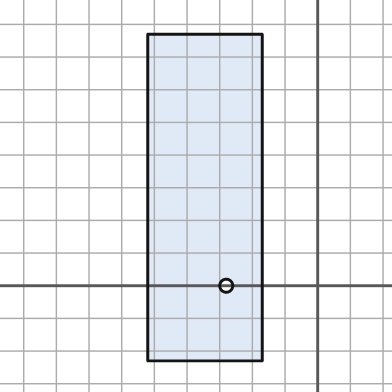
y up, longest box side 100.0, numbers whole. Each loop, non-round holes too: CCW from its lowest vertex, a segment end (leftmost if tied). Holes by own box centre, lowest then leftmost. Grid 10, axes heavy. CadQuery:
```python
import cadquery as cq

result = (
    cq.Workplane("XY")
    .moveTo(-52.0, -23.0)
    .lineTo(-17.0, -23.0)
    .lineTo(-17.0, 77.0)
    .lineTo(-52.0, 77.0)
    .close()
    .moveTo(-28.0, 0.0)
    .circle(2.0)
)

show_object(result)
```